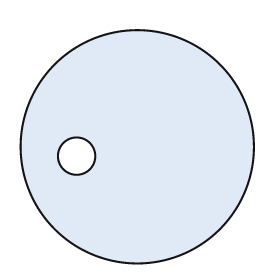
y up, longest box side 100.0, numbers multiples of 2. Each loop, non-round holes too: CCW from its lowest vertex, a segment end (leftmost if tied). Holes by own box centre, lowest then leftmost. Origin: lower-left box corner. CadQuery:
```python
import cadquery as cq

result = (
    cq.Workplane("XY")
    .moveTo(50.0, 50.0)
    .circle(50.0)
    .moveTo(24.0, 46.0)
    .circle(8.0)
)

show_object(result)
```